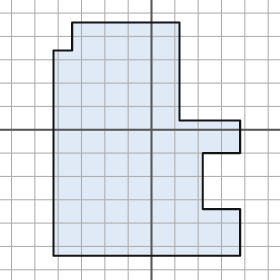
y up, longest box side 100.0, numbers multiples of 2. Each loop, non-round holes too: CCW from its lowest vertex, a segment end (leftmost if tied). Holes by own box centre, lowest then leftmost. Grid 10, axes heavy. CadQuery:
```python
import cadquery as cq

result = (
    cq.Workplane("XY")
    .moveTo(-42.0, -54.0)
    .lineTo(38.0, -54.0)
    .lineTo(38.0, -34.0)
    .lineTo(22.0, -34.0)
    .lineTo(22.0, -10.0)
    .lineTo(38.0, -10.0)
    .lineTo(38.0, 4.0)
    .lineTo(12.0, 4.0)
    .lineTo(12.0, 46.0)
    .lineTo(-34.0, 46.0)
    .lineTo(-34.0, 34.0)
    .lineTo(-42.0, 34.0)
    .close()
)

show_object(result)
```